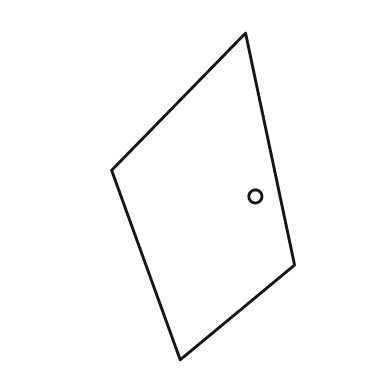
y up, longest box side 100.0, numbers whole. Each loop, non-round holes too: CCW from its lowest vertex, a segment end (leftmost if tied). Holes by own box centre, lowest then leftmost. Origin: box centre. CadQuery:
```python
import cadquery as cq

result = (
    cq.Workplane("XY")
    .moveTo(-7.0, -50.0)
    .lineTo(28.0, -21.0)
    .lineTo(13.0, 50.0)
    .lineTo(-28.0, 8.0)
    .close()
    .moveTo(16.0, 0.0)
    .circle(2.0)
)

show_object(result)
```